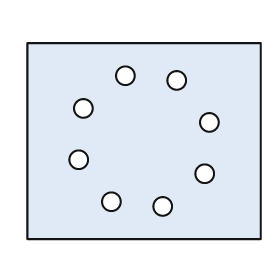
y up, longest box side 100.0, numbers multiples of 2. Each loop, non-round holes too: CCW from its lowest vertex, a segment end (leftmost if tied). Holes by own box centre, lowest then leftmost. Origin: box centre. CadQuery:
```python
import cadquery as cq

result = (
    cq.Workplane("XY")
    .moveTo(-50.0, -42.0)
    .lineTo(50.0, -42.0)
    .lineTo(50.0, 42.0)
    .lineTo(-50.0, 42.0)
    .close()
    .moveTo(8.0, -28.0)
    .circle(4.0)
    .moveTo(-14.0, -26.0)
    .circle(4.0)
    .moveTo(26.0, -14.0)
    .circle(4.0)
    .moveTo(-28.0, -8.0)
    .circle(4.0)
    .moveTo(28.0, 8.0)
    .circle(4.0)
    .moveTo(-26.0, 14.0)
    .circle(4.0)
    .moveTo(14.0, 26.0)
    .circle(4.0)
    .moveTo(-8.0, 28.0)
    .circle(4.0)
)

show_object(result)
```